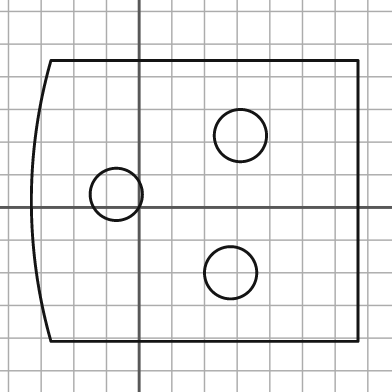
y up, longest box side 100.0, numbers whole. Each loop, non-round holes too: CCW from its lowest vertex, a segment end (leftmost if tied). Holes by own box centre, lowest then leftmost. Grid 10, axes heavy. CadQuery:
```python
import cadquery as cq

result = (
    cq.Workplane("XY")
    .moveTo(-27.0, -41.0)
    .lineTo(67.0, -41.0)
    .lineTo(67.0, 45.0)
    .lineTo(-27.0, 45.0)
    .threePointArc((-33.0, 2.0), (-27.0, -41.0))
    .close()
    .moveTo(28.0, -20.0)
    .circle(8.0)
    .moveTo(-7.0, 4.0)
    .circle(8.0)
    .moveTo(31.0, 22.0)
    .circle(8.0)
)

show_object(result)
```